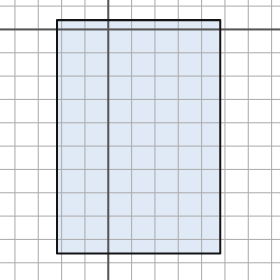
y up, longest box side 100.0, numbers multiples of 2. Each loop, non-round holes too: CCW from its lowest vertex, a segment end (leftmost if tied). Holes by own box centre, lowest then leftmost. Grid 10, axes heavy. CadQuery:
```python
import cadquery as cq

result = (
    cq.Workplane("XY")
    .moveTo(-22.0, -96.0)
    .lineTo(48.0, -96.0)
    .lineTo(48.0, 4.0)
    .lineTo(-22.0, 4.0)
    .close()
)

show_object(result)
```